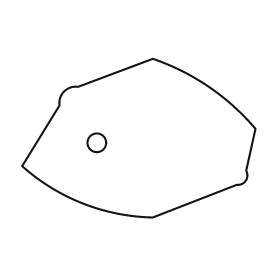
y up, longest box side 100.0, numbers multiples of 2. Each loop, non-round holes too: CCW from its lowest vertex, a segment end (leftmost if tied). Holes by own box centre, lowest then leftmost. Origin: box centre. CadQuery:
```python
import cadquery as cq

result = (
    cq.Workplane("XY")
    .moveTo(6.0, -34.0)
    .lineTo(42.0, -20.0)
    .threePointArc((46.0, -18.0), (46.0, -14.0))
    .lineTo(50.0, 4.0)
    .threePointArc((30.0, 22.0), (6.0, 34.0))
    .lineTo(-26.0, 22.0)
    .threePointArc((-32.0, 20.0), (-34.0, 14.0))
    .lineTo(-50.0, -12.0)
    .threePointArc((-24.0, -28.0), (6.0, -34.0))
    .close()
    .moveTo(-18.0, -2.0)
    .circle(4.0)
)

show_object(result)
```